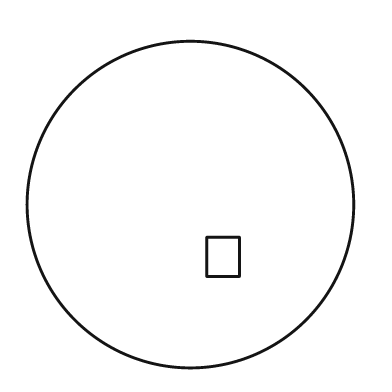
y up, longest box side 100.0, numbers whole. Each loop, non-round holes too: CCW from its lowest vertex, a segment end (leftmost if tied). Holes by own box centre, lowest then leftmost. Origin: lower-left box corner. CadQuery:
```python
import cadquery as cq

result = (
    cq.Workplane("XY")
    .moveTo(50.0, 50.0)
    .circle(50.0)
    .moveTo(55.0, 28.0)
    .lineTo(65.0, 28.0)
    .lineTo(65.0, 40.0)
    .lineTo(55.0, 40.0)
    .close()
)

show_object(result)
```